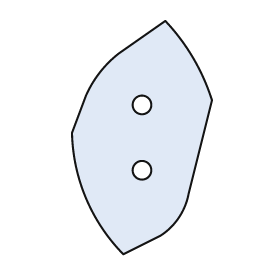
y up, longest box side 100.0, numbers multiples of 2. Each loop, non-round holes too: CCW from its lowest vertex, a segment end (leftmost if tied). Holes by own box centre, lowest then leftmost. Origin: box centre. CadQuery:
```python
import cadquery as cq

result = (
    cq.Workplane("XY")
    .moveTo(-8.0, -50.0)
    .lineTo(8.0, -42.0)
    .threePointArc((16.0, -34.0), (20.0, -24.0))
    .lineTo(30.0, 16.0)
    .threePointArc((22.0, 34.0), (10.0, 50.0))
    .lineTo(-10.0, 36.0)
    .threePointArc((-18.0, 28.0), (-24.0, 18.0))
    .lineTo(-30.0, 2.0)
    .threePointArc((-24.0, -26.0), (-8.0, -50.0))
    .close()
    .moveTo(0.0, -14.0)
    .circle(4.0)
    .moveTo(0.0, 14.0)
    .circle(4.0)
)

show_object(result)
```